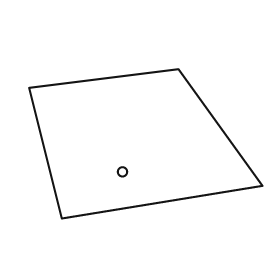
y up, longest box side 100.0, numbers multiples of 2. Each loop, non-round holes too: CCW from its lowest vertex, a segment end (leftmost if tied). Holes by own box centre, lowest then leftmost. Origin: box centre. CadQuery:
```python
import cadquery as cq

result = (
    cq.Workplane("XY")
    .moveTo(-36.0, -32.0)
    .lineTo(50.0, -18.0)
    .lineTo(14.0, 32.0)
    .lineTo(-50.0, 24.0)
    .close()
    .moveTo(-10.0, -12.0)
    .circle(2.0)
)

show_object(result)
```